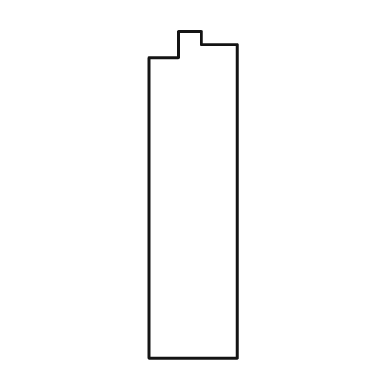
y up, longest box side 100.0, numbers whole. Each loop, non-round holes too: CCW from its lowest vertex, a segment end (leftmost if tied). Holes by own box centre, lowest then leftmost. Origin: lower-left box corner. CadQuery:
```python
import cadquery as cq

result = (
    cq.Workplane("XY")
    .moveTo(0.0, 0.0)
    .lineTo(27.0, 0.0)
    .lineTo(27.0, 96.0)
    .lineTo(16.0, 96.0)
    .lineTo(16.0, 100.0)
    .lineTo(9.0, 100.0)
    .lineTo(9.0, 92.0)
    .lineTo(0.0, 92.0)
    .close()
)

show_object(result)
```